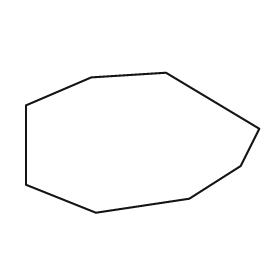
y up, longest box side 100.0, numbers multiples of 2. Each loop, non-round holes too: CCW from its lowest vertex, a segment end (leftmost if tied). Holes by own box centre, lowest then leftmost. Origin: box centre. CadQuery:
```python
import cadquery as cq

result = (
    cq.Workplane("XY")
    .moveTo(-20.0, -30.0)
    .lineTo(20.0, -24.0)
    .lineTo(42.0, -10.0)
    .lineTo(50.0, 6.0)
    .lineTo(10.0, 30.0)
    .lineTo(-22.0, 28.0)
    .lineTo(-50.0, 16.0)
    .lineTo(-50.0, -18.0)
    .close()
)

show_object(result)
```